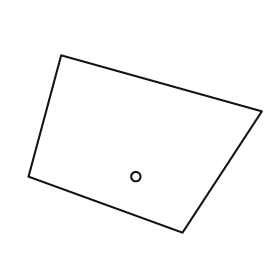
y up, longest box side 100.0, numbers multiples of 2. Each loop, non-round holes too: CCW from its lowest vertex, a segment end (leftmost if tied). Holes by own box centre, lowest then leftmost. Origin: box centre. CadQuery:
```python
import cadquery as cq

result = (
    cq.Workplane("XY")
    .moveTo(16.0, -38.0)
    .lineTo(50.0, 14.0)
    .lineTo(-36.0, 38.0)
    .lineTo(-50.0, -14.0)
    .close()
    .moveTo(-4.0, -14.0)
    .circle(2.0)
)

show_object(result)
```